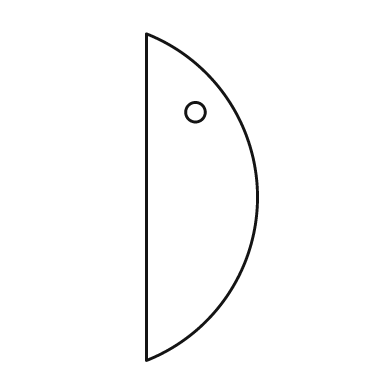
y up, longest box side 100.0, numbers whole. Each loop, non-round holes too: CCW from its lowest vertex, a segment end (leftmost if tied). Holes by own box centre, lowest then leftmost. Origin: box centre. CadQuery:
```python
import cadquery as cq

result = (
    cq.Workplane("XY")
    .moveTo(-17.0, -50.0)
    .threePointArc((17.0, 0.0), (-17.0, 50.0))
    .close()
    .moveTo(-2.0, 26.0)
    .circle(3.0)
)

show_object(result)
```